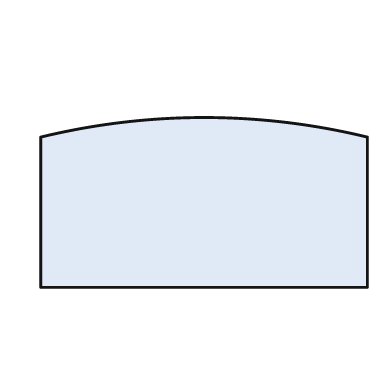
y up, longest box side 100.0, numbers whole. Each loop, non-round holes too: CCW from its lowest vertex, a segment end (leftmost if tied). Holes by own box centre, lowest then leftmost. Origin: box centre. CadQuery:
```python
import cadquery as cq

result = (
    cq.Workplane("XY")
    .moveTo(-50.0, -26.0)
    .lineTo(50.0, -26.0)
    .lineTo(50.0, 20.0)
    .threePointArc((0.0, 26.0), (-50.0, 20.0))
    .close()
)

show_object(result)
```